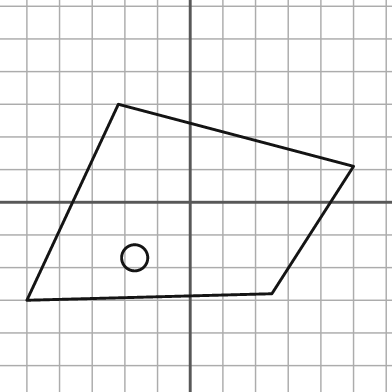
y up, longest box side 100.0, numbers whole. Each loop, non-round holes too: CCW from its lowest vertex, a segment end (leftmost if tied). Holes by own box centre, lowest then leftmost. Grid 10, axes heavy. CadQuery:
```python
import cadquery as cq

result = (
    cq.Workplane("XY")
    .moveTo(-50.0, -30.0)
    .lineTo(25.0, -28.0)
    .lineTo(50.0, 11.0)
    .lineTo(-22.0, 30.0)
    .close()
    .moveTo(-17.0, -17.0)
    .circle(4.0)
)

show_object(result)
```